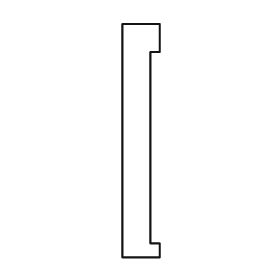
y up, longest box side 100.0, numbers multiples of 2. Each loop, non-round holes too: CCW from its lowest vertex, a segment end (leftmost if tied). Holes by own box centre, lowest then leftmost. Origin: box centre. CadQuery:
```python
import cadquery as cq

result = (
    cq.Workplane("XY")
    .moveTo(-8.0, -50.0)
    .lineTo(8.0, -50.0)
    .lineTo(8.0, -44.0)
    .lineTo(4.0, -44.0)
    .lineTo(4.0, 38.0)
    .lineTo(8.0, 38.0)
    .lineTo(8.0, 50.0)
    .lineTo(-8.0, 50.0)
    .close()
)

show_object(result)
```